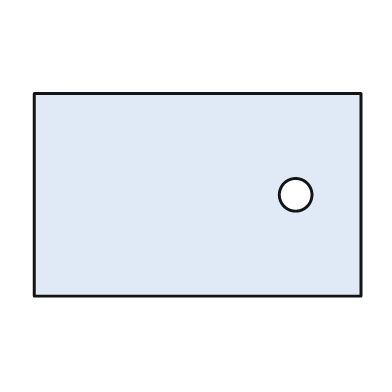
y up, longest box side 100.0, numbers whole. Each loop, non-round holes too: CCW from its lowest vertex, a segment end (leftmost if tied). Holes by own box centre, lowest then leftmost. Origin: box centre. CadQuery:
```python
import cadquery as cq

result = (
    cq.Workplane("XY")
    .moveTo(-50.0, -31.0)
    .lineTo(50.0, -31.0)
    .lineTo(50.0, 31.0)
    .lineTo(-50.0, 31.0)
    .close()
    .moveTo(30.0, 0.0)
    .circle(5.0)
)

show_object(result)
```